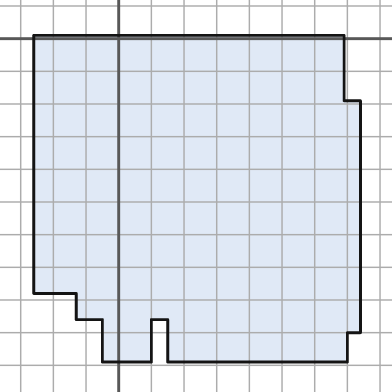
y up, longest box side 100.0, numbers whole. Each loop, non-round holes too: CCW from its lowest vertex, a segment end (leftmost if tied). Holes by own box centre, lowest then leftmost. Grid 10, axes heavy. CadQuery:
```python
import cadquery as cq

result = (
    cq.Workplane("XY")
    .moveTo(-5.0, -99.0)
    .lineTo(10.0, -99.0)
    .lineTo(10.0, -86.0)
    .lineTo(15.0, -86.0)
    .lineTo(15.0, -99.0)
    .lineTo(70.0, -99.0)
    .lineTo(70.0, -90.0)
    .lineTo(74.0, -90.0)
    .lineTo(74.0, -19.0)
    .lineTo(69.0, -19.0)
    .lineTo(69.0, 1.0)
    .lineTo(-26.0, 1.0)
    .lineTo(-26.0, -78.0)
    .lineTo(-13.0, -78.0)
    .lineTo(-13.0, -86.0)
    .lineTo(-5.0, -86.0)
    .close()
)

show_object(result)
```